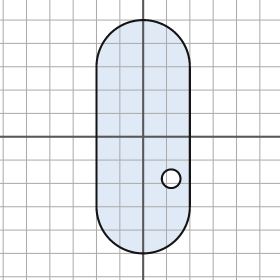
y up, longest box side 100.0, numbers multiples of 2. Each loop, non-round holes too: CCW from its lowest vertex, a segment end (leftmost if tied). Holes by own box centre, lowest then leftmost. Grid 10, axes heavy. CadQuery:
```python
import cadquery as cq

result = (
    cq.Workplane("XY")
    .moveTo(-20.0, -30.0)
    .threePointArc((0.0, -50.0), (20.0, -30.0))
    .lineTo(20.0, 30.0)
    .threePointArc((0.0, 50.0), (-20.0, 30.0))
    .close()
    .moveTo(12.0, -18.0)
    .circle(4.0)
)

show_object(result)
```